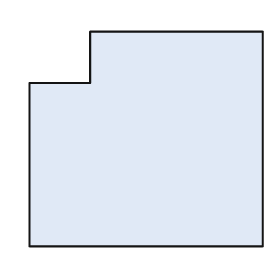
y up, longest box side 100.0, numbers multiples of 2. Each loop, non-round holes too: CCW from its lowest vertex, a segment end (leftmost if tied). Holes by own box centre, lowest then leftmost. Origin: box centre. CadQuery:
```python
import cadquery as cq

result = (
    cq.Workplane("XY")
    .moveTo(-50.0, -46.0)
    .lineTo(50.0, -46.0)
    .lineTo(50.0, 46.0)
    .lineTo(-24.0, 46.0)
    .lineTo(-24.0, 24.0)
    .lineTo(-50.0, 24.0)
    .close()
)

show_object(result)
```